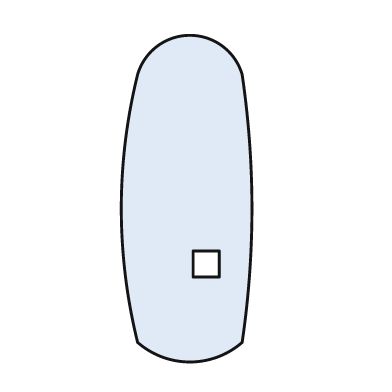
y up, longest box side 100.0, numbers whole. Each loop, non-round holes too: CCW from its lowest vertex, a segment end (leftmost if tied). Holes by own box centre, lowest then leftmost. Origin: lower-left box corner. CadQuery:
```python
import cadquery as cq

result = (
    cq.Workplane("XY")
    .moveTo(5.0, 6.0)
    .threePointArc((21.0, 0.0), (37.0, 6.0))
    .threePointArc((40.0, 47.0), (37.0, 88.0))
    .threePointArc((21.0, 100.0), (5.0, 88.0))
    .threePointArc((0.0, 47.0), (5.0, 6.0))
    .close()
    .moveTo(22.0, 26.0)
    .lineTo(30.0, 26.0)
    .lineTo(30.0, 34.0)
    .lineTo(22.0, 34.0)
    .close()
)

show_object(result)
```